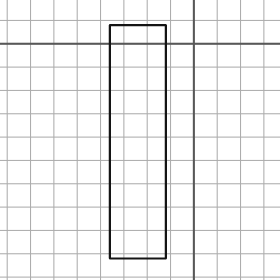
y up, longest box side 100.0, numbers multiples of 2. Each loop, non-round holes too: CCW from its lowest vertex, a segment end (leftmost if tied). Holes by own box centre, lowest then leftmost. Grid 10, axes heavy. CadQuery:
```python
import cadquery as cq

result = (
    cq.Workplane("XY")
    .moveTo(-36.0, -92.0)
    .lineTo(-12.0, -92.0)
    .lineTo(-12.0, 8.0)
    .lineTo(-36.0, 8.0)
    .close()
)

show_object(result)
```